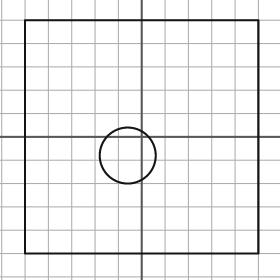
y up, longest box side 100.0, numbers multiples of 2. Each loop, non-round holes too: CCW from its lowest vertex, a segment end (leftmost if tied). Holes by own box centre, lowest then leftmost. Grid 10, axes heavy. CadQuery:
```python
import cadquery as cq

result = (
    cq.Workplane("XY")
    .moveTo(-50.0, -50.0)
    .lineTo(50.0, -50.0)
    .lineTo(50.0, 50.0)
    .lineTo(-50.0, 50.0)
    .close()
    .moveTo(-6.0, -8.0)
    .circle(12.0)
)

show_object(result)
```